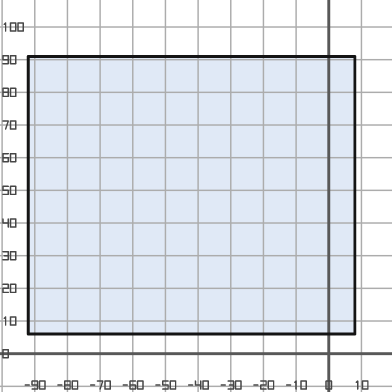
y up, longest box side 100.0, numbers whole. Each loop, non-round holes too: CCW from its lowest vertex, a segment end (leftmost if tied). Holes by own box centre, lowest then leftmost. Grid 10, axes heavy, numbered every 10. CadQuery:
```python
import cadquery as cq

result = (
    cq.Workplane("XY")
    .moveTo(-92.0, 6.0)
    .lineTo(8.0, 6.0)
    .lineTo(8.0, 91.0)
    .lineTo(-92.0, 91.0)
    .close()
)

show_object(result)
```